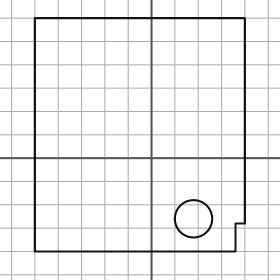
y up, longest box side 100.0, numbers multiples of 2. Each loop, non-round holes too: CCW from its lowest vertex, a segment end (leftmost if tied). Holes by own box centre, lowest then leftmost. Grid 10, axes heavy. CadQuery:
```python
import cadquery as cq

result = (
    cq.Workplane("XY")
    .moveTo(-50.0, -40.0)
    .lineTo(36.0, -40.0)
    .lineTo(36.0, -28.0)
    .lineTo(40.0, -28.0)
    .lineTo(40.0, 60.0)
    .lineTo(-50.0, 60.0)
    .close()
    .moveTo(18.0, -26.0)
    .circle(8.0)
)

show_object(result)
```